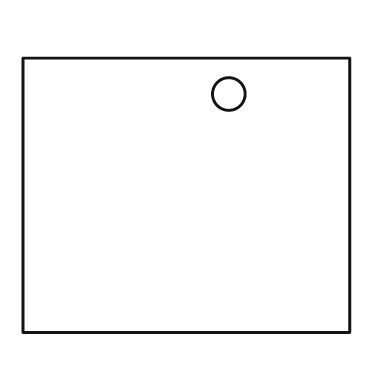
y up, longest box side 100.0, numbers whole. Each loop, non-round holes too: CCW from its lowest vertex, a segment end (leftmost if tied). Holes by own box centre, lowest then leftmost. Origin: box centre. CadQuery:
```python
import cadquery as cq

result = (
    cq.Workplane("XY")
    .moveTo(-50.0, -42.0)
    .lineTo(50.0, -42.0)
    .lineTo(50.0, 42.0)
    .lineTo(-50.0, 42.0)
    .close()
    .moveTo(13.0, 31.0)
    .circle(5.0)
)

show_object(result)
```